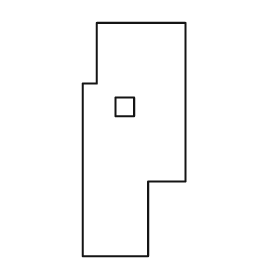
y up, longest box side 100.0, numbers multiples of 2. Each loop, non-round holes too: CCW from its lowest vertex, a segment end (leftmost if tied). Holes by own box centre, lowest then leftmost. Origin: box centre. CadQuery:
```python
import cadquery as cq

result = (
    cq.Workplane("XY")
    .moveTo(-22.0, -50.0)
    .lineTo(6.0, -50.0)
    .lineTo(6.0, -18.0)
    .lineTo(22.0, -18.0)
    .lineTo(22.0, 50.0)
    .lineTo(-16.0, 50.0)
    .lineTo(-16.0, 24.0)
    .lineTo(-22.0, 24.0)
    .close()
    .moveTo(-8.0, 10.0)
    .lineTo(0.0, 10.0)
    .lineTo(0.0, 18.0)
    .lineTo(-8.0, 18.0)
    .close()
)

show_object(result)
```